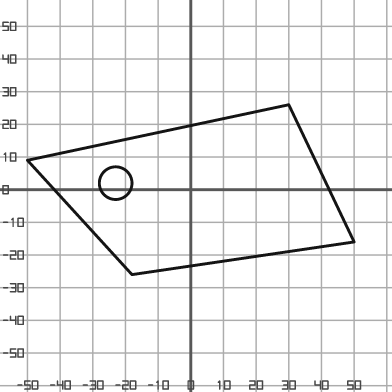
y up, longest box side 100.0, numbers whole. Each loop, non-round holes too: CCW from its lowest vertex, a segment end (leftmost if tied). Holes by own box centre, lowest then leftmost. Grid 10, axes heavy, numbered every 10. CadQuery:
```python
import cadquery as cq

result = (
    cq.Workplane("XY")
    .moveTo(-18.0, -26.0)
    .lineTo(50.0, -16.0)
    .lineTo(30.0, 26.0)
    .lineTo(-50.0, 9.0)
    .close()
    .moveTo(-23.0, 2.0)
    .circle(5.0)
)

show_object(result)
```